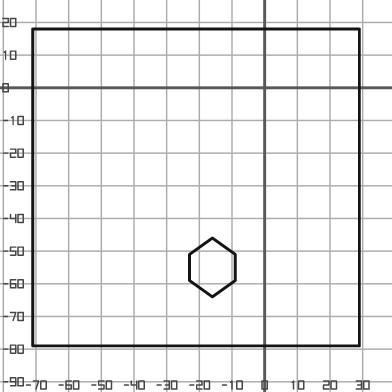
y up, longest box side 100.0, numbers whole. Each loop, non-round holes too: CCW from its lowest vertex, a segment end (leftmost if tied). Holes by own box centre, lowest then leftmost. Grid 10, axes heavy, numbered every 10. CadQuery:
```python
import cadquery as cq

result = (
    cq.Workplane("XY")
    .moveTo(-71.0, -79.0)
    .lineTo(29.0, -79.0)
    .lineTo(29.0, 18.0)
    .lineTo(-71.0, 18.0)
    .close()
    .moveTo(-16.0, -64.0)
    .lineTo(-9.0, -59.0)
    .lineTo(-9.0, -51.0)
    .lineTo(-16.0, -46.0)
    .lineTo(-23.0, -51.0)
    .lineTo(-23.0, -59.0)
    .close()
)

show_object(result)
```